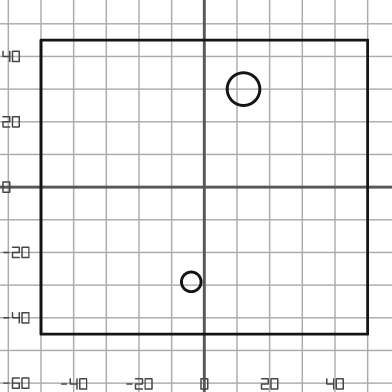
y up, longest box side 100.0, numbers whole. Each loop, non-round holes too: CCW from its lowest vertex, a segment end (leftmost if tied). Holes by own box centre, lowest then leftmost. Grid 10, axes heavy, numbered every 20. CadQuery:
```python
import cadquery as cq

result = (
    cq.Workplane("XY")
    .moveTo(-50.0, -45.0)
    .lineTo(50.0, -45.0)
    .lineTo(50.0, 45.0)
    .lineTo(-50.0, 45.0)
    .close()
    .moveTo(-4.0, -29.0)
    .circle(3.0)
    .moveTo(12.0, 30.0)
    .circle(5.0)
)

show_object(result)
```